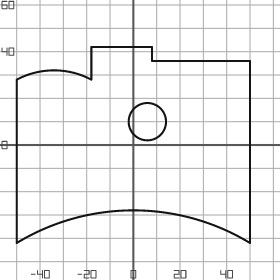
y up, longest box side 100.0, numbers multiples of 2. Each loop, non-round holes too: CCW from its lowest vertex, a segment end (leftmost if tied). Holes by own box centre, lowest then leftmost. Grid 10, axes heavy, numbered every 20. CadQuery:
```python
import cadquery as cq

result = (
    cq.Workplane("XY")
    .moveTo(-50.0, -42.0)
    .threePointArc((0.0, -28.0), (50.0, -42.0))
    .lineTo(50.0, 36.0)
    .lineTo(8.0, 36.0)
    .lineTo(8.0, 42.0)
    .lineTo(-18.0, 42.0)
    .lineTo(-18.0, 28.0)
    .threePointArc((-34.0, 32.0), (-50.0, 28.0))
    .close()
    .moveTo(6.0, 10.0)
    .circle(8.0)
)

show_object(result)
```